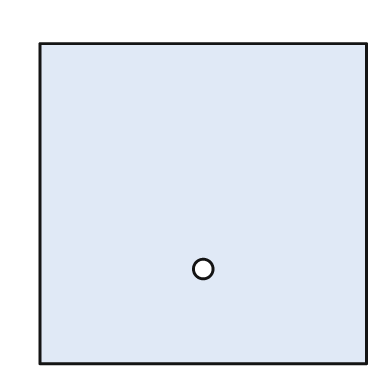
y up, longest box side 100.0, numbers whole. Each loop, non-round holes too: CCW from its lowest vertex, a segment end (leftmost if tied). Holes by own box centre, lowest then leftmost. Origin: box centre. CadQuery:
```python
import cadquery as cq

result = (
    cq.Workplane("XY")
    .moveTo(-50.0, -49.0)
    .lineTo(50.0, -49.0)
    .lineTo(50.0, 49.0)
    .lineTo(-50.0, 49.0)
    .close()
    .moveTo(0.0, -20.0)
    .circle(3.0)
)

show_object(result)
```